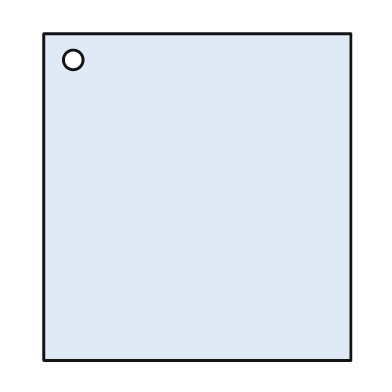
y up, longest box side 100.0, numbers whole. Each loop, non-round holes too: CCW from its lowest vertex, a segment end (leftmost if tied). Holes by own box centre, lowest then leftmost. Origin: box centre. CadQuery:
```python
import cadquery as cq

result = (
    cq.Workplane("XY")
    .moveTo(-47.0, -50.0)
    .lineTo(47.0, -50.0)
    .lineTo(47.0, 50.0)
    .lineTo(-47.0, 50.0)
    .close()
    .moveTo(-38.0, 42.0)
    .circle(3.0)
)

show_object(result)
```